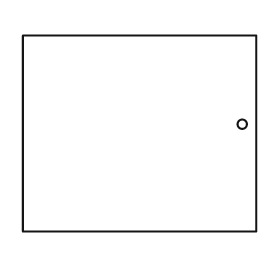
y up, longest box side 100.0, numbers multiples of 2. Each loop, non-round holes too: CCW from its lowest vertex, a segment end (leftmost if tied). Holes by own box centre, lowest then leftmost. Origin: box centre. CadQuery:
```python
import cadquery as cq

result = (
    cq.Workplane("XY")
    .moveTo(-50.0, -42.0)
    .lineTo(50.0, -42.0)
    .lineTo(50.0, 42.0)
    .lineTo(-50.0, 42.0)
    .close()
    .moveTo(44.0, 4.0)
    .circle(2.0)
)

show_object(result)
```